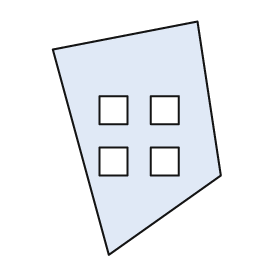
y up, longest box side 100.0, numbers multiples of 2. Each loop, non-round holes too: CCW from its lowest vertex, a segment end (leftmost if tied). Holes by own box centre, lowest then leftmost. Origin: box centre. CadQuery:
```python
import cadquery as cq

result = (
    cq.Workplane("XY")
    .moveTo(-12.0, -50.0)
    .lineTo(36.0, -16.0)
    .lineTo(26.0, 50.0)
    .lineTo(-36.0, 38.0)
    .close()
    .moveTo(-16.0, -16.0)
    .lineTo(-4.0, -16.0)
    .lineTo(-4.0, -4.0)
    .lineTo(-16.0, -4.0)
    .close()
    .moveTo(6.0, -16.0)
    .lineTo(18.0, -16.0)
    .lineTo(18.0, -4.0)
    .lineTo(6.0, -4.0)
    .close()
    .moveTo(-16.0, 6.0)
    .lineTo(-4.0, 6.0)
    .lineTo(-4.0, 18.0)
    .lineTo(-16.0, 18.0)
    .close()
    .moveTo(6.0, 6.0)
    .lineTo(18.0, 6.0)
    .lineTo(18.0, 18.0)
    .lineTo(6.0, 18.0)
    .close()
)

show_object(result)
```